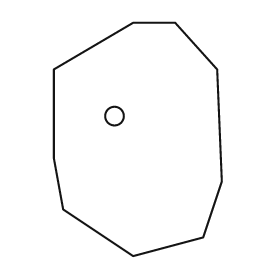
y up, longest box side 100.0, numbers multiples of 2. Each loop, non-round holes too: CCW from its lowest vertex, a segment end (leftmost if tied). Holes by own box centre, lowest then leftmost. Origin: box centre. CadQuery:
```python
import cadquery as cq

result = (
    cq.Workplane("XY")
    .moveTo(-2.0, -50.0)
    .lineTo(28.0, -42.0)
    .lineTo(36.0, -18.0)
    .lineTo(34.0, 30.0)
    .lineTo(16.0, 50.0)
    .lineTo(-2.0, 50.0)
    .lineTo(-36.0, 30.0)
    .lineTo(-36.0, -8.0)
    .lineTo(-32.0, -30.0)
    .close()
    .moveTo(-10.0, 10.0)
    .circle(4.0)
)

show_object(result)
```